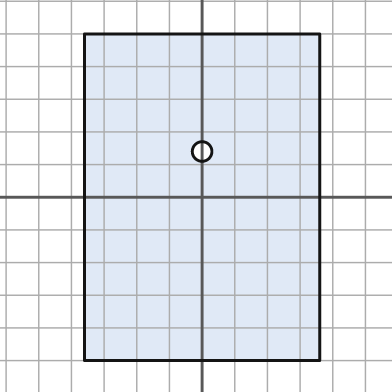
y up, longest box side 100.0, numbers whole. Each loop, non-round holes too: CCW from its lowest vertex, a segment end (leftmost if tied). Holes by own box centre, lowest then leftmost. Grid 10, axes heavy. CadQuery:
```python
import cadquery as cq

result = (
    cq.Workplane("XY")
    .moveTo(-36.0, -50.0)
    .lineTo(36.0, -50.0)
    .lineTo(36.0, 50.0)
    .lineTo(-36.0, 50.0)
    .close()
    .moveTo(0.0, 14.0)
    .circle(3.0)
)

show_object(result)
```